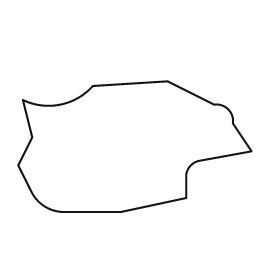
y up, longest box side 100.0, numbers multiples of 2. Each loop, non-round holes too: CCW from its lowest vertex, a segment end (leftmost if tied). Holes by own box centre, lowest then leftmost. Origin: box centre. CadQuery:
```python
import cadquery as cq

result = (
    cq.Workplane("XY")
    .moveTo(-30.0, -28.0)
    .lineTo(-6.0, -28.0)
    .lineTo(22.0, -22.0)
    .lineTo(22.0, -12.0)
    .threePointArc((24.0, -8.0), (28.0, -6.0))
    .lineTo(50.0, -2.0)
    .lineTo(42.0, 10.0)
    .threePointArc((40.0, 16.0), (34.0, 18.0))
    .lineTo(14.0, 28.0)
    .lineTo(-18.0, 26.0)
    .threePointArc((-32.0, 18.0), (-48.0, 20.0))
    .lineTo(-44.0, 4.0)
    .lineTo(-50.0, -8.0)
    .lineTo(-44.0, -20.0)
    .threePointArc((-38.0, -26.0), (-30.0, -28.0))
    .close()
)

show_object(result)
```